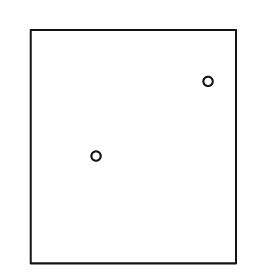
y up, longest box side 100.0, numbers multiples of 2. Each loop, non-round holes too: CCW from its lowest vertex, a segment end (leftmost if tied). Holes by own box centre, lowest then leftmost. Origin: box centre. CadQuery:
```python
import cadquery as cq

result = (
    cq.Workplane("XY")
    .moveTo(-44.0, -50.0)
    .lineTo(44.0, -50.0)
    .lineTo(44.0, 50.0)
    .lineTo(-44.0, 50.0)
    .close()
    .moveTo(-16.0, -4.0)
    .circle(2.0)
    .moveTo(32.0, 28.0)
    .circle(2.0)
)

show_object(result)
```